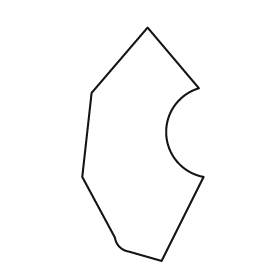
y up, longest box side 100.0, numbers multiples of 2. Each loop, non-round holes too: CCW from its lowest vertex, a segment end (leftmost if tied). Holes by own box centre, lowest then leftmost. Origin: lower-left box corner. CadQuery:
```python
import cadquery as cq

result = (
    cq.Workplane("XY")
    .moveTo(34.0, 0.0)
    .lineTo(52.0, 36.0)
    .threePointArc((36.0, 54.0), (50.0, 74.0))
    .lineTo(28.0, 100.0)
    .lineTo(4.0, 72.0)
    .lineTo(0.0, 36.0)
    .lineTo(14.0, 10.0)
    .threePointArc((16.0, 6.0), (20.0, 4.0))
    .close()
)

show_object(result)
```